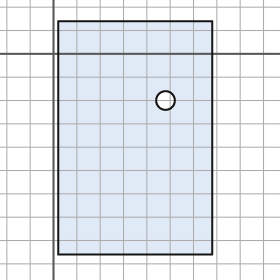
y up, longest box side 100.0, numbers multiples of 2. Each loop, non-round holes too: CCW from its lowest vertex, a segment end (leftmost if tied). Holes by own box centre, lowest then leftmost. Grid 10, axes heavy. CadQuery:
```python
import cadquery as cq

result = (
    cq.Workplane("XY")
    .moveTo(2.0, -86.0)
    .lineTo(68.0, -86.0)
    .lineTo(68.0, 14.0)
    .lineTo(2.0, 14.0)
    .close()
    .moveTo(48.0, -20.0)
    .circle(4.0)
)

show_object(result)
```